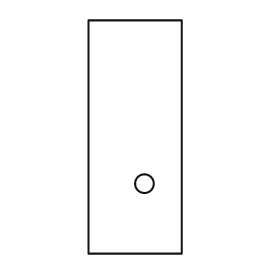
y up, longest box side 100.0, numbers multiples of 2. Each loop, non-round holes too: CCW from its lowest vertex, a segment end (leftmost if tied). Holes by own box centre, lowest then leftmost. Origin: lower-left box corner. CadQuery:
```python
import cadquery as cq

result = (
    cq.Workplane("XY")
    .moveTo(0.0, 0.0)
    .lineTo(40.0, 0.0)
    .lineTo(40.0, 100.0)
    .lineTo(0.0, 100.0)
    .close()
    .moveTo(24.0, 30.0)
    .circle(4.0)
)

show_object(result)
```